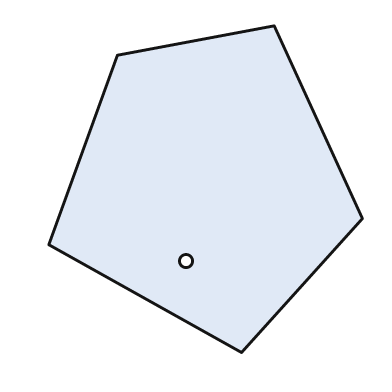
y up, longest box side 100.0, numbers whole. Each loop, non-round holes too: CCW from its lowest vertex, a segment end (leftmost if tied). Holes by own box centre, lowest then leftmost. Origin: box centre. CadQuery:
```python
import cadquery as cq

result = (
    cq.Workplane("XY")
    .moveTo(11.0, -50.0)
    .lineTo(48.0, -9.0)
    .lineTo(21.0, 50.0)
    .lineTo(-27.0, 41.0)
    .lineTo(-48.0, -17.0)
    .close()
    .moveTo(-6.0, -22.0)
    .circle(2.0)
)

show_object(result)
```